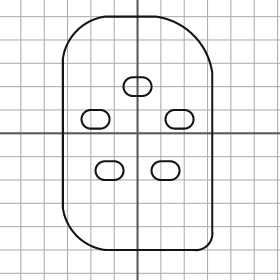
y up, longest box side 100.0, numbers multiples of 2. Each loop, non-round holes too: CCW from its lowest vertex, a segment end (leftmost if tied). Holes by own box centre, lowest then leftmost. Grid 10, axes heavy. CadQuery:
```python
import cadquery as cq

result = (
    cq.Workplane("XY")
    .moveTo(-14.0, -50.0)
    .lineTo(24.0, -50.0)
    .threePointArc((30.0, -48.0), (32.0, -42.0))
    .lineTo(32.0, 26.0)
    .threePointArc((24.0, 42.0), (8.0, 50.0))
    .lineTo(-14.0, 50.0)
    .threePointArc((-26.0, 44.0), (-32.0, 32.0))
    .lineTo(-32.0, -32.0)
    .threePointArc((-26.0, -44.0), (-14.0, -50.0))
    .close()
    .moveTo(-14.0, -20.0)
    .lineTo(-10.0, -20.0)
    .threePointArc((-6.0, -16.0), (-10.0, -12.0))
    .lineTo(-14.0, -12.0)
    .threePointArc((-18.0, -16.0), (-14.0, -20.0))
    .close()
    .moveTo(10.0, -20.0)
    .lineTo(14.0, -20.0)
    .threePointArc((18.0, -16.0), (14.0, -12.0))
    .lineTo(10.0, -12.0)
    .threePointArc((6.0, -16.0), (10.0, -20.0))
    .close()
    .moveTo(-20.0, 2.0)
    .lineTo(-16.0, 2.0)
    .threePointArc((-12.0, 6.0), (-16.0, 10.0))
    .lineTo(-20.0, 10.0)
    .threePointArc((-24.0, 6.0), (-20.0, 2.0))
    .close()
    .moveTo(16.0, 2.0)
    .lineTo(20.0, 2.0)
    .threePointArc((24.0, 6.0), (20.0, 10.0))
    .lineTo(16.0, 10.0)
    .threePointArc((12.0, 6.0), (16.0, 2.0))
    .close()
    .moveTo(-2.0, 16.0)
    .lineTo(2.0, 16.0)
    .threePointArc((6.0, 20.0), (2.0, 24.0))
    .lineTo(-2.0, 24.0)
    .threePointArc((-6.0, 20.0), (-2.0, 16.0))
    .close()
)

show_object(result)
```